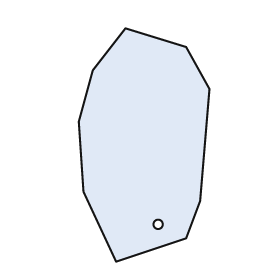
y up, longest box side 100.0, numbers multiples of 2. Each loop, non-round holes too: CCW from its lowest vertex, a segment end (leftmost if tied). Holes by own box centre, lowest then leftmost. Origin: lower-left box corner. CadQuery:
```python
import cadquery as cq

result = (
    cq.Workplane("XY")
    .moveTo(16.0, 0.0)
    .lineTo(46.0, 10.0)
    .lineTo(52.0, 26.0)
    .lineTo(56.0, 74.0)
    .lineTo(46.0, 92.0)
    .lineTo(20.0, 100.0)
    .lineTo(6.0, 82.0)
    .lineTo(0.0, 60.0)
    .lineTo(2.0, 30.0)
    .close()
    .moveTo(34.0, 16.0)
    .circle(2.0)
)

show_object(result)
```